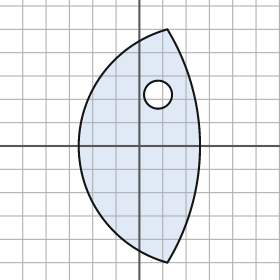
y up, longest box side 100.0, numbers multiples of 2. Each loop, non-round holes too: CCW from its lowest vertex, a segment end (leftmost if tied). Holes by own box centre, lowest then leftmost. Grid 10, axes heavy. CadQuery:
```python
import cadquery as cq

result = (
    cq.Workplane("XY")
    .moveTo(12.0, -50.0)
    .threePointArc((26.0, 0.0), (12.0, 50.0))
    .threePointArc((-26.0, 0.0), (12.0, -50.0))
    .close()
    .moveTo(8.0, 22.0)
    .circle(6.0)
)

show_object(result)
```